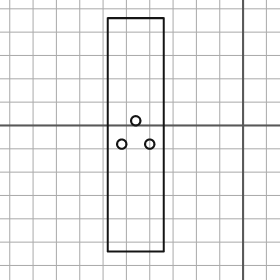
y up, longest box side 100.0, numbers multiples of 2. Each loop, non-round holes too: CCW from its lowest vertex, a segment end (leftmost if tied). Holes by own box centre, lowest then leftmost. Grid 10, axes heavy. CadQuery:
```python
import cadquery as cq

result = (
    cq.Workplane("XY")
    .moveTo(-58.0, -54.0)
    .lineTo(-34.0, -54.0)
    .lineTo(-34.0, 46.0)
    .lineTo(-58.0, 46.0)
    .close()
    .moveTo(-52.0, -8.0)
    .circle(2.0)
    .moveTo(-40.0, -8.0)
    .circle(2.0)
    .moveTo(-46.0, 2.0)
    .circle(2.0)
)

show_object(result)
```